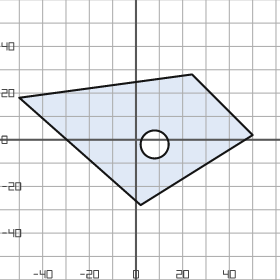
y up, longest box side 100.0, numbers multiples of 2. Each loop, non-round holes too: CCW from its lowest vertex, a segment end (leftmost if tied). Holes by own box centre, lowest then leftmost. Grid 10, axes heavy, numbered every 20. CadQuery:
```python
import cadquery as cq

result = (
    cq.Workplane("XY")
    .moveTo(2.0, -28.0)
    .lineTo(50.0, 2.0)
    .lineTo(24.0, 28.0)
    .lineTo(-50.0, 18.0)
    .close()
    .moveTo(8.0, -2.0)
    .circle(6.0)
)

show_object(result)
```